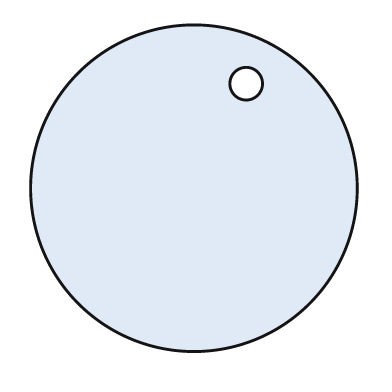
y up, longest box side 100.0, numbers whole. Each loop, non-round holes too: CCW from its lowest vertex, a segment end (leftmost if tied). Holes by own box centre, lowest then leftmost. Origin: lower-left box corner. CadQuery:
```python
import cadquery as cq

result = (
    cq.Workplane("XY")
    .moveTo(50.0, 50.0)
    .circle(50.0)
    .moveTo(66.0, 82.0)
    .circle(5.0)
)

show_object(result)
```